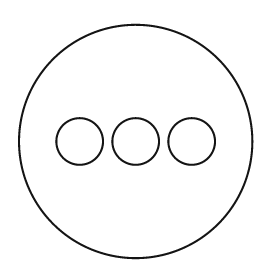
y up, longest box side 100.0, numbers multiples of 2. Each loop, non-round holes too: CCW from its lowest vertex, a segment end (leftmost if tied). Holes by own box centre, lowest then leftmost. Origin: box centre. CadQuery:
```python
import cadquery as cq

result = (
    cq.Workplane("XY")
    .moveTo(0.0, 0.0)
    .circle(50.0)
    .moveTo(-24.0, 0.0)
    .circle(10.0)
    .moveTo(0.0, 0.0)
    .circle(10.0)
    .moveTo(24.0, 0.0)
    .circle(10.0)
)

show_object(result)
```